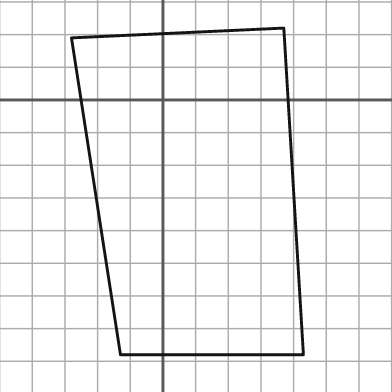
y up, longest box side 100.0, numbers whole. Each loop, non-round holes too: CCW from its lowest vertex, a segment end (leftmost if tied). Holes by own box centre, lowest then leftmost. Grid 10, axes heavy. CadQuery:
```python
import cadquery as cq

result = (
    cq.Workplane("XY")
    .moveTo(-13.0, -78.0)
    .lineTo(43.0, -78.0)
    .lineTo(37.0, 22.0)
    .lineTo(-28.0, 19.0)
    .close()
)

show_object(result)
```